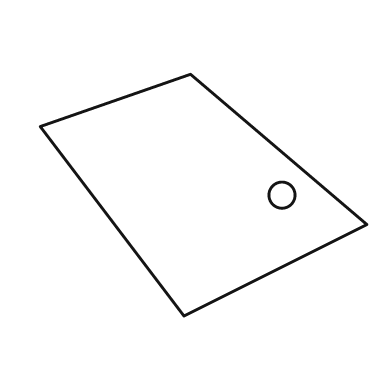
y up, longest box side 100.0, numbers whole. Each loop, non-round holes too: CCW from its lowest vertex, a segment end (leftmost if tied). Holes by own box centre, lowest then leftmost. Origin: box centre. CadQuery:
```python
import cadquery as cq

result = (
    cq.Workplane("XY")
    .moveTo(-6.0, -37.0)
    .lineTo(50.0, -9.0)
    .lineTo(-4.0, 37.0)
    .lineTo(-50.0, 21.0)
    .close()
    .moveTo(24.0, 0.0)
    .circle(4.0)
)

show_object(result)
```